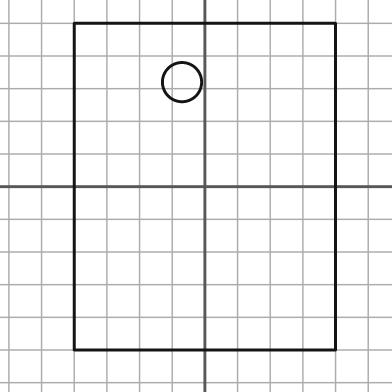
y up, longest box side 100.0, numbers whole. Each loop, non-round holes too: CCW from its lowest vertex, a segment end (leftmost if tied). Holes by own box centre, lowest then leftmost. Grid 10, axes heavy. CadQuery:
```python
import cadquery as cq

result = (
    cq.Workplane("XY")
    .moveTo(-40.0, -50.0)
    .lineTo(40.0, -50.0)
    .lineTo(40.0, 50.0)
    .lineTo(-40.0, 50.0)
    .close()
    .moveTo(-7.0, 32.0)
    .circle(6.0)
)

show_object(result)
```